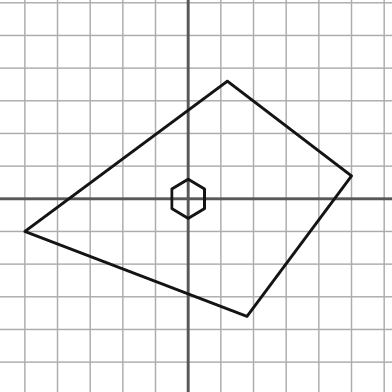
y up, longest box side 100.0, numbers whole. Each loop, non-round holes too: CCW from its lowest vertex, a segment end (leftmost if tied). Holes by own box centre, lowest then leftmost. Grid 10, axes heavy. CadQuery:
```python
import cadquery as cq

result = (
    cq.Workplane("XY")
    .moveTo(18.0, -36.0)
    .lineTo(50.0, 7.0)
    .lineTo(12.0, 36.0)
    .lineTo(-50.0, -10.0)
    .close()
    .moveTo(0.0, -6.0)
    .lineTo(5.0, -3.0)
    .lineTo(5.0, 3.0)
    .lineTo(0.0, 6.0)
    .lineTo(-5.0, 3.0)
    .lineTo(-5.0, -3.0)
    .close()
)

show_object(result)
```